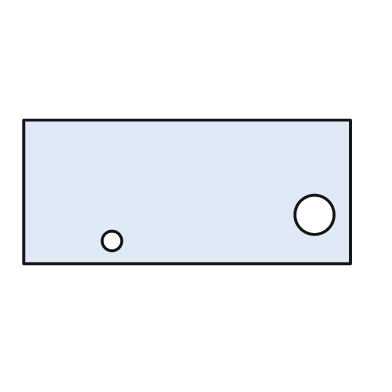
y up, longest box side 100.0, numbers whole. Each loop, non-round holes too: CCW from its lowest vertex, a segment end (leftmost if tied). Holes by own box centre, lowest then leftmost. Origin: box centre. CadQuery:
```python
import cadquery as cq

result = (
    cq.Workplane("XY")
    .moveTo(-50.0, -22.0)
    .lineTo(50.0, -22.0)
    .lineTo(50.0, 22.0)
    .lineTo(-50.0, 22.0)
    .close()
    .moveTo(-23.0, -15.0)
    .circle(3.0)
    .moveTo(39.0, -7.0)
    .circle(6.0)
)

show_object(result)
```